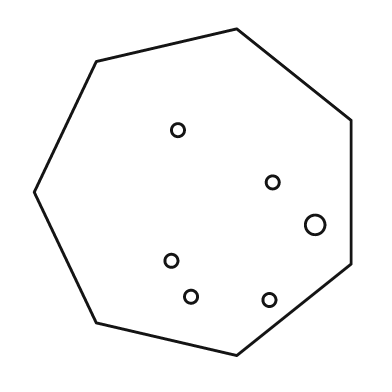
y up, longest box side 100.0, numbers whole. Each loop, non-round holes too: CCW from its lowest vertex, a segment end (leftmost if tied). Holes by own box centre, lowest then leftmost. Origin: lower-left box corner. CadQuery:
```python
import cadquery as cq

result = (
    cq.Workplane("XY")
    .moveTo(62.0, 0.0)
    .lineTo(97.0, 28.0)
    .lineTo(97.0, 72.0)
    .lineTo(62.0, 100.0)
    .lineTo(19.0, 90.0)
    .lineTo(0.0, 50.0)
    .lineTo(19.0, 10.0)
    .close()
    .moveTo(72.0, 17.0)
    .circle(2.0)
    .moveTo(48.0, 18.0)
    .circle(2.0)
    .moveTo(42.0, 29.0)
    .circle(2.0)
    .moveTo(86.0, 40.0)
    .circle(3.0)
    .moveTo(73.0, 53.0)
    .circle(2.0)
    .moveTo(44.0, 69.0)
    .circle(2.0)
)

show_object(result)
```